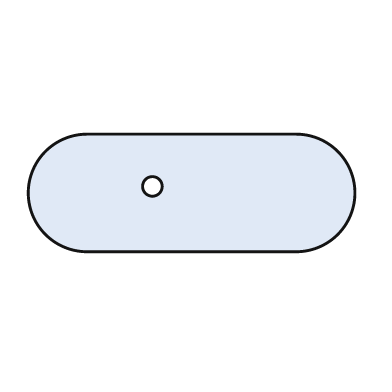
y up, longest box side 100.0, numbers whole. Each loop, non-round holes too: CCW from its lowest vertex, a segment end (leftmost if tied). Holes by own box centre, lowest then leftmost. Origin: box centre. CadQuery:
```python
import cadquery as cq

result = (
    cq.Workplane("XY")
    .moveTo(-32.0, -18.0)
    .lineTo(32.0, -18.0)
    .threePointArc((50.0, 0.0), (32.0, 18.0))
    .lineTo(-32.0, 18.0)
    .threePointArc((-50.0, 0.0), (-32.0, -18.0))
    .close()
    .moveTo(-12.0, 2.0)
    .circle(3.0)
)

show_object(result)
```